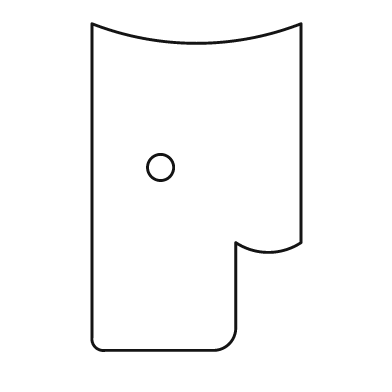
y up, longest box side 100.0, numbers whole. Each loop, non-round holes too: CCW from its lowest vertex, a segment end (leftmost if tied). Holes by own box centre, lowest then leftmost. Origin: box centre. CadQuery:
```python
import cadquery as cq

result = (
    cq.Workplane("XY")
    .moveTo(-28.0, -50.0)
    .lineTo(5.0, -50.0)
    .threePointArc((10.0, -48.0), (12.0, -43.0))
    .lineTo(12.0, -17.0)
    .threePointArc((22.0, -20.0), (32.0, -17.0))
    .lineTo(32.0, 50.0)
    .threePointArc((0.0, 44.0), (-32.0, 50.0))
    .lineTo(-32.0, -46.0)
    .threePointArc((-31.0, -49.0), (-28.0, -50.0))
    .close()
    .moveTo(-11.0, 6.0)
    .circle(4.0)
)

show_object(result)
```